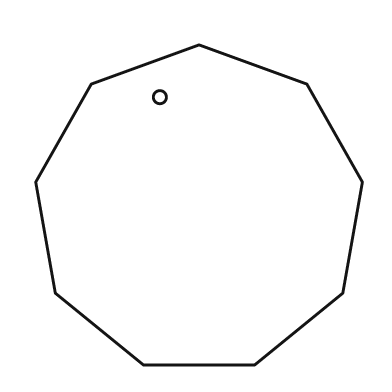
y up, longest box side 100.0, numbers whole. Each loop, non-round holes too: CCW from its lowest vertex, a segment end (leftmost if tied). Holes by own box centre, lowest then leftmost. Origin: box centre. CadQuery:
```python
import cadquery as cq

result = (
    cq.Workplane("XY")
    .moveTo(-17.0, -49.0)
    .lineTo(17.0, -49.0)
    .lineTo(44.0, -27.0)
    .lineTo(50.0, 7.0)
    .lineTo(33.0, 37.0)
    .lineTo(0.0, 49.0)
    .lineTo(-33.0, 37.0)
    .lineTo(-50.0, 7.0)
    .lineTo(-44.0, -27.0)
    .close()
    .moveTo(-12.0, 33.0)
    .circle(2.0)
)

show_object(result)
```